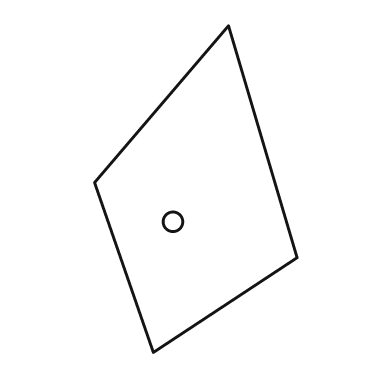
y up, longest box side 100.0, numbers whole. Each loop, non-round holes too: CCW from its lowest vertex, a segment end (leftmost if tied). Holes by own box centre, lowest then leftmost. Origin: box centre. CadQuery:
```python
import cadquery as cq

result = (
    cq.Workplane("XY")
    .moveTo(-13.0, -50.0)
    .lineTo(31.0, -21.0)
    .lineTo(10.0, 50.0)
    .lineTo(-31.0, 2.0)
    .close()
    .moveTo(-7.0, -10.0)
    .circle(3.0)
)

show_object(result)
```